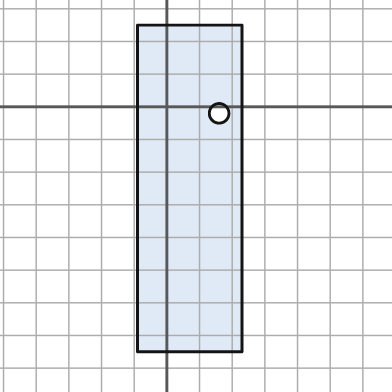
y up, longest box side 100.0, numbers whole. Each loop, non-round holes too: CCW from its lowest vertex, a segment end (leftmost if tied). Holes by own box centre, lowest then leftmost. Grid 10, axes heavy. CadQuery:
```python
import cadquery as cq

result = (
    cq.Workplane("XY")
    .moveTo(-9.0, -75.0)
    .lineTo(23.0, -75.0)
    .lineTo(23.0, 25.0)
    .lineTo(-9.0, 25.0)
    .close()
    .moveTo(16.0, -2.0)
    .circle(3.0)
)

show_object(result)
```